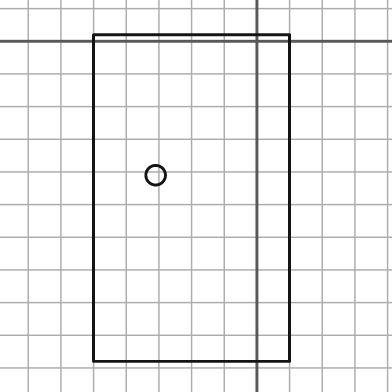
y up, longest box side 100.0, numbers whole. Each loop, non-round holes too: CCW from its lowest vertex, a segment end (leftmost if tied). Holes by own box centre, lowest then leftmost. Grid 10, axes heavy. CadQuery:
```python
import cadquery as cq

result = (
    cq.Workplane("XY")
    .moveTo(-50.0, -98.0)
    .lineTo(10.0, -98.0)
    .lineTo(10.0, 2.0)
    .lineTo(-50.0, 2.0)
    .close()
    .moveTo(-31.0, -41.0)
    .circle(3.0)
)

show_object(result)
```